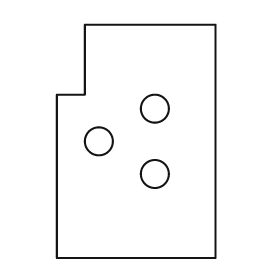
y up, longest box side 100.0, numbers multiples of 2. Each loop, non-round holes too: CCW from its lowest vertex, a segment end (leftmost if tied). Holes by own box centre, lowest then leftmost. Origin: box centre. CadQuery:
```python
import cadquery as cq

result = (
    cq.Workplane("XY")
    .moveTo(-34.0, -50.0)
    .lineTo(34.0, -50.0)
    .lineTo(34.0, 50.0)
    .lineTo(-22.0, 50.0)
    .lineTo(-22.0, 20.0)
    .lineTo(-34.0, 20.0)
    .close()
    .moveTo(8.0, -14.0)
    .circle(6.0)
    .moveTo(-16.0, 0.0)
    .circle(6.0)
    .moveTo(8.0, 14.0)
    .circle(6.0)
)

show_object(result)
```